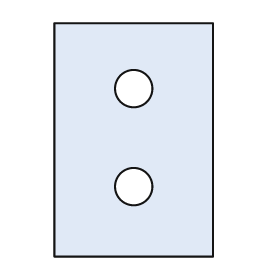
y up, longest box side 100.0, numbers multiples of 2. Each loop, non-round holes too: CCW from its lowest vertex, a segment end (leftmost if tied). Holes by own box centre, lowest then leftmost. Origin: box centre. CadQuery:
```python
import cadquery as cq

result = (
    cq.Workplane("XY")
    .moveTo(-34.0, -50.0)
    .lineTo(34.0, -50.0)
    .lineTo(34.0, 50.0)
    .lineTo(-34.0, 50.0)
    .close()
    .moveTo(0.0, -20.0)
    .circle(8.0)
    .moveTo(0.0, 22.0)
    .circle(8.0)
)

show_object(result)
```